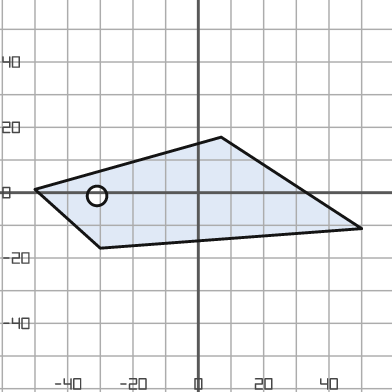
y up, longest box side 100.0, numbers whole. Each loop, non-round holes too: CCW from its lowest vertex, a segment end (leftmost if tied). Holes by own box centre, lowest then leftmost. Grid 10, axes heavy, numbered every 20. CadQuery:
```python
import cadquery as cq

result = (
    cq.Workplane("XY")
    .moveTo(-30.0, -17.0)
    .lineTo(50.0, -11.0)
    .lineTo(7.0, 17.0)
    .lineTo(-50.0, 1.0)
    .close()
    .moveTo(-31.0, -1.0)
    .circle(3.0)
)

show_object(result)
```